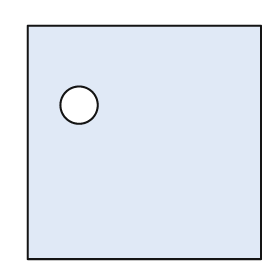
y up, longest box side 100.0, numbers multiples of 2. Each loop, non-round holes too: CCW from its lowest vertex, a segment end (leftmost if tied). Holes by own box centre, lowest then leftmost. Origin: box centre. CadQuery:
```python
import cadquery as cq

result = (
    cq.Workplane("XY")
    .moveTo(-50.0, -50.0)
    .lineTo(50.0, -50.0)
    .lineTo(50.0, 50.0)
    .lineTo(-50.0, 50.0)
    .close()
    .moveTo(-28.0, 16.0)
    .circle(8.0)
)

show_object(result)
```